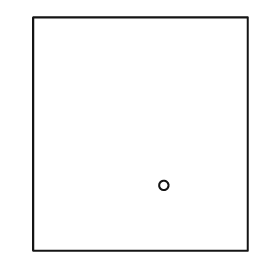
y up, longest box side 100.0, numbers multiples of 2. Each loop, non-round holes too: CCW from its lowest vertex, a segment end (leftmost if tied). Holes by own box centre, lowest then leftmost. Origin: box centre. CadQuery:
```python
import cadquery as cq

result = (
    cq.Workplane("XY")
    .moveTo(-46.0, -50.0)
    .lineTo(46.0, -50.0)
    .lineTo(46.0, 50.0)
    .lineTo(-46.0, 50.0)
    .close()
    .moveTo(10.0, -22.0)
    .circle(2.0)
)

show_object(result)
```